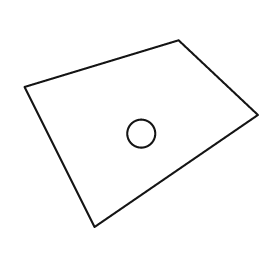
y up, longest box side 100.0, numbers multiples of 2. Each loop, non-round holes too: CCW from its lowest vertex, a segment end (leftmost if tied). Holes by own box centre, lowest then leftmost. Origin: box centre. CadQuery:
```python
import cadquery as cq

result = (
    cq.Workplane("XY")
    .moveTo(-20.0, -40.0)
    .lineTo(50.0, 8.0)
    .lineTo(16.0, 40.0)
    .lineTo(-50.0, 20.0)
    .close()
    .moveTo(0.0, 0.0)
    .circle(6.0)
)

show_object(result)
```